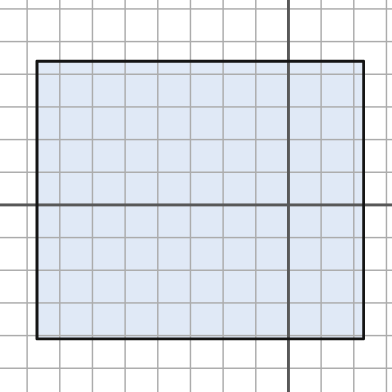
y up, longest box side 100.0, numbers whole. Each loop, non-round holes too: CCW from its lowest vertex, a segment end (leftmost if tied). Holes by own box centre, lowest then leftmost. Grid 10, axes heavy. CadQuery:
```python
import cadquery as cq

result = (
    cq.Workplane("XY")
    .moveTo(-77.0, -41.0)
    .lineTo(23.0, -41.0)
    .lineTo(23.0, 44.0)
    .lineTo(-77.0, 44.0)
    .close()
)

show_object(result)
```